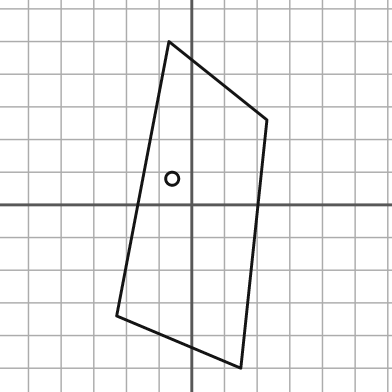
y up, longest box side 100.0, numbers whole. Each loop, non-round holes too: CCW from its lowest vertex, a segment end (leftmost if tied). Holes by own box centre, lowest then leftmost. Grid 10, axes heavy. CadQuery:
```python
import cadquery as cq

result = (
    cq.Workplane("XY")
    .moveTo(15.0, -50.0)
    .lineTo(23.0, 26.0)
    .lineTo(-7.0, 50.0)
    .lineTo(-23.0, -34.0)
    .close()
    .moveTo(-6.0, 8.0)
    .circle(2.0)
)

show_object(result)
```